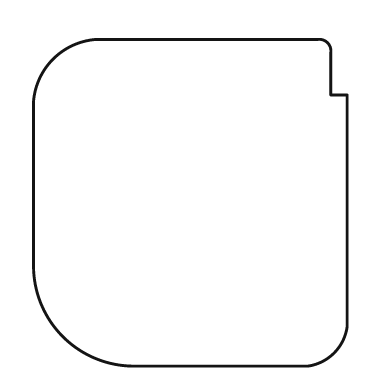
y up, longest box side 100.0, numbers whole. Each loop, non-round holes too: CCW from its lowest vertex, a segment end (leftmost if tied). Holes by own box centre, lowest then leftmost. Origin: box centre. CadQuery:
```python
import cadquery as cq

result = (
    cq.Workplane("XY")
    .moveTo(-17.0, -50.0)
    .lineTo(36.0, -50.0)
    .threePointArc((44.0, -46.0), (48.0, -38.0))
    .lineTo(48.0, 33.0)
    .lineTo(43.0, 33.0)
    .lineTo(43.0, 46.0)
    .threePointArc((42.0, 49.0), (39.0, 50.0))
    .lineTo(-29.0, 50.0)
    .threePointArc((-42.0, 44.0), (-48.0, 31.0))
    .lineTo(-48.0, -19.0)
    .threePointArc((-39.0, -41.0), (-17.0, -50.0))
    .close()
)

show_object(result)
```